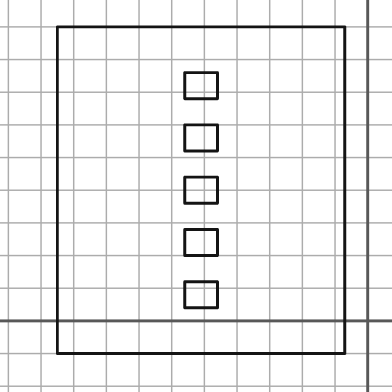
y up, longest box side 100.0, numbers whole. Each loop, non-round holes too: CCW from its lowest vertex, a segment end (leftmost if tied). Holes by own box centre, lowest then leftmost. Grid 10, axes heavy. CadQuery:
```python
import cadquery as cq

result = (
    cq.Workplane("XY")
    .moveTo(-95.0, -10.0)
    .lineTo(-7.0, -10.0)
    .lineTo(-7.0, 90.0)
    .lineTo(-95.0, 90.0)
    .close()
    .moveTo(-56.0, 4.0)
    .lineTo(-46.0, 4.0)
    .lineTo(-46.0, 12.0)
    .lineTo(-56.0, 12.0)
    .close()
    .moveTo(-56.0, 20.0)
    .lineTo(-46.0, 20.0)
    .lineTo(-46.0, 28.0)
    .lineTo(-56.0, 28.0)
    .close()
    .moveTo(-56.0, 36.0)
    .lineTo(-46.0, 36.0)
    .lineTo(-46.0, 44.0)
    .lineTo(-56.0, 44.0)
    .close()
    .moveTo(-56.0, 52.0)
    .lineTo(-46.0, 52.0)
    .lineTo(-46.0, 60.0)
    .lineTo(-56.0, 60.0)
    .close()
    .moveTo(-56.0, 68.0)
    .lineTo(-46.0, 68.0)
    .lineTo(-46.0, 76.0)
    .lineTo(-56.0, 76.0)
    .close()
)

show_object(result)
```